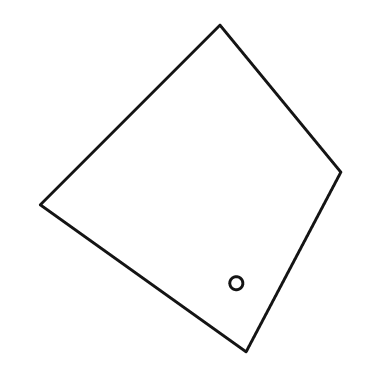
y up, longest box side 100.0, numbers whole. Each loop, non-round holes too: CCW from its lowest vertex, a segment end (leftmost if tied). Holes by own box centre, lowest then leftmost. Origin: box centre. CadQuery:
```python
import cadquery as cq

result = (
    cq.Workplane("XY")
    .moveTo(17.0, -50.0)
    .lineTo(46.0, 5.0)
    .lineTo(9.0, 50.0)
    .lineTo(-46.0, -5.0)
    .close()
    .moveTo(14.0, -29.0)
    .circle(2.0)
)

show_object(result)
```